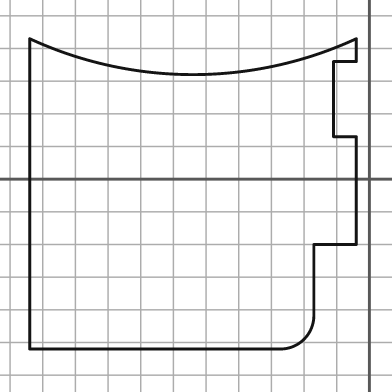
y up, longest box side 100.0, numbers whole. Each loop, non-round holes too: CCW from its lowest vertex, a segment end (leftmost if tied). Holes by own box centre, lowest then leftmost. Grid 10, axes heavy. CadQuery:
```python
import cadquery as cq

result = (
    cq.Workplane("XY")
    .moveTo(-104.0, -52.0)
    .lineTo(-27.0, -52.0)
    .threePointArc((-20.0, -49.0), (-17.0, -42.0))
    .lineTo(-17.0, -20.0)
    .lineTo(-4.0, -20.0)
    .lineTo(-4.0, 13.0)
    .lineTo(-11.0, 13.0)
    .lineTo(-11.0, 36.0)
    .lineTo(-4.0, 36.0)
    .lineTo(-4.0, 43.0)
    .threePointArc((-54.0, 32.0), (-104.0, 43.0))
    .close()
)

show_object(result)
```